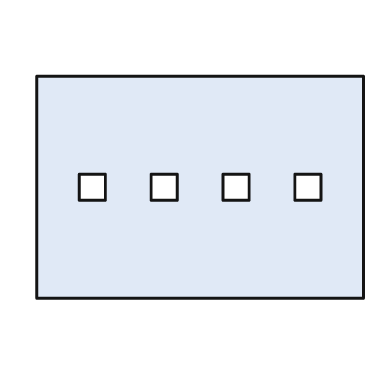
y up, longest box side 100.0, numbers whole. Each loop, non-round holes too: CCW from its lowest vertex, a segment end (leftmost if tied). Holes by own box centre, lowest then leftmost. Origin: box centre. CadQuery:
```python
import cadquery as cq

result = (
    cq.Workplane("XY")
    .moveTo(-50.0, -34.0)
    .lineTo(50.0, -34.0)
    .lineTo(50.0, 34.0)
    .lineTo(-50.0, 34.0)
    .close()
    .moveTo(-37.0, -4.0)
    .lineTo(-29.0, -4.0)
    .lineTo(-29.0, 4.0)
    .lineTo(-37.0, 4.0)
    .close()
    .moveTo(-15.0, -4.0)
    .lineTo(-7.0, -4.0)
    .lineTo(-7.0, 4.0)
    .lineTo(-15.0, 4.0)
    .close()
    .moveTo(7.0, -4.0)
    .lineTo(15.0, -4.0)
    .lineTo(15.0, 4.0)
    .lineTo(7.0, 4.0)
    .close()
    .moveTo(29.0, -4.0)
    .lineTo(37.0, -4.0)
    .lineTo(37.0, 4.0)
    .lineTo(29.0, 4.0)
    .close()
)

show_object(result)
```